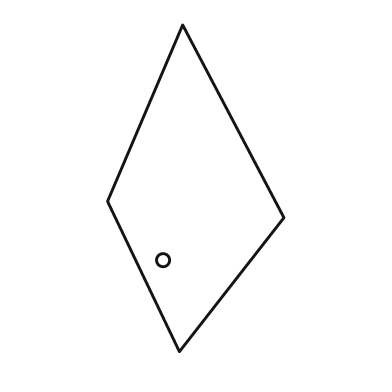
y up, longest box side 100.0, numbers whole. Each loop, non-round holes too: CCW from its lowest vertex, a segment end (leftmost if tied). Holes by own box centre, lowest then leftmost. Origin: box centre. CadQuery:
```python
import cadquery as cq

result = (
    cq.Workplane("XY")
    .moveTo(-5.0, -50.0)
    .lineTo(27.0, -9.0)
    .lineTo(-4.0, 50.0)
    .lineTo(-27.0, -4.0)
    .close()
    .moveTo(-10.0, -22.0)
    .circle(2.0)
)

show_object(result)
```